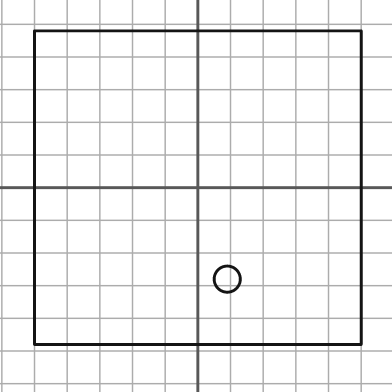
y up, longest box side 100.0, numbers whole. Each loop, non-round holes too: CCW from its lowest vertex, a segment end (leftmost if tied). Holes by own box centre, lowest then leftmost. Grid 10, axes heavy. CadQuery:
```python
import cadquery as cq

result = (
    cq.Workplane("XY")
    .moveTo(-50.0, -48.0)
    .lineTo(50.0, -48.0)
    .lineTo(50.0, 48.0)
    .lineTo(-50.0, 48.0)
    .close()
    .moveTo(9.0, -28.0)
    .circle(4.0)
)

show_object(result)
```